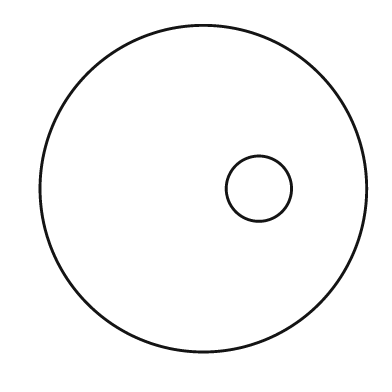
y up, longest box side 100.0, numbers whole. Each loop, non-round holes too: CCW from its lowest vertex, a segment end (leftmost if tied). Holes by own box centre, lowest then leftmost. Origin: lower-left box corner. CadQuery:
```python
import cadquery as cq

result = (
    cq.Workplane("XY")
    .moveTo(50.0, 50.0)
    .circle(50.0)
    .moveTo(67.0, 50.0)
    .circle(10.0)
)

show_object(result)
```